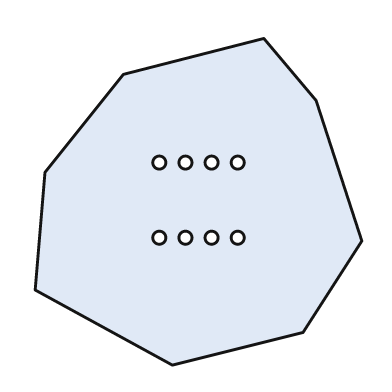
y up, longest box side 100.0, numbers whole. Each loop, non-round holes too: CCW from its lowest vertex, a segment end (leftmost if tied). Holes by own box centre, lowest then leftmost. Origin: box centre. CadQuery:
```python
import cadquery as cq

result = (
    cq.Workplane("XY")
    .moveTo(-8.0, -50.0)
    .lineTo(32.0, -40.0)
    .lineTo(50.0, -12.0)
    .lineTo(36.0, 31.0)
    .lineTo(20.0, 50.0)
    .lineTo(-23.0, 39.0)
    .lineTo(-47.0, 9.0)
    .lineTo(-50.0, -27.0)
    .close()
    .moveTo(-12.0, -11.0)
    .circle(2.0)
    .moveTo(-4.0, -11.0)
    .circle(2.0)
    .moveTo(4.0, -11.0)
    .circle(2.0)
    .moveTo(12.0, -11.0)
    .circle(2.0)
    .moveTo(-12.0, 12.0)
    .circle(2.0)
    .moveTo(-4.0, 12.0)
    .circle(2.0)
    .moveTo(4.0, 12.0)
    .circle(2.0)
    .moveTo(12.0, 12.0)
    .circle(2.0)
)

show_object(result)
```